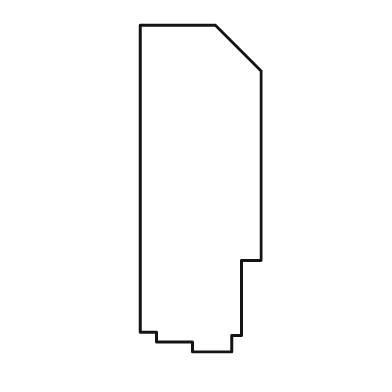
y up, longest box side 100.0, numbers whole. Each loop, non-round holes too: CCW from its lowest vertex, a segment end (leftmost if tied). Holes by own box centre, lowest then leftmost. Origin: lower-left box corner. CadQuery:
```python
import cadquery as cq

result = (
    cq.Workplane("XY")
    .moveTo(16.0, 0.0)
    .lineTo(28.0, 0.0)
    .lineTo(28.0, 5.0)
    .lineTo(31.0, 5.0)
    .lineTo(31.0, 28.0)
    .lineTo(37.0, 28.0)
    .lineTo(37.0, 86.0)
    .lineTo(23.0, 100.0)
    .lineTo(0.0, 100.0)
    .lineTo(0.0, 6.0)
    .lineTo(5.0, 6.0)
    .lineTo(5.0, 3.0)
    .lineTo(16.0, 3.0)
    .close()
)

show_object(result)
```